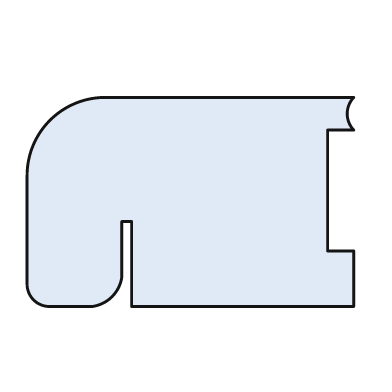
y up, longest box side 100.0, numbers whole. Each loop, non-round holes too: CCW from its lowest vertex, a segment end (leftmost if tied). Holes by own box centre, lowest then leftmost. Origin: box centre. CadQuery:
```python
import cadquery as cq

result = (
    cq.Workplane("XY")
    .moveTo(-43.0, -32.0)
    .lineTo(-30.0, -32.0)
    .threePointArc((-24.0, -29.0), (-21.0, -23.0))
    .lineTo(-21.0, -6.0)
    .lineTo(-18.0, -6.0)
    .lineTo(-18.0, -32.0)
    .lineTo(50.0, -32.0)
    .lineTo(50.0, -15.0)
    .lineTo(42.0, -15.0)
    .lineTo(42.0, 22.0)
    .lineTo(50.0, 22.0)
    .threePointArc((48.0, 27.0), (50.0, 32.0))
    .lineTo(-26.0, 32.0)
    .threePointArc((-43.0, 25.0), (-50.0, 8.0))
    .lineTo(-50.0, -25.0)
    .threePointArc((-48.0, -30.0), (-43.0, -32.0))
    .close()
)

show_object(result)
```